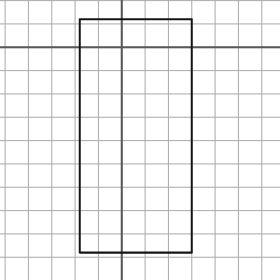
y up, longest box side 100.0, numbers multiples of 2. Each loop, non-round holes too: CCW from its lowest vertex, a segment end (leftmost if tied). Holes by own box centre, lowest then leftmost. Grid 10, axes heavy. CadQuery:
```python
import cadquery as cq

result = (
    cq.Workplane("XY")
    .moveTo(-18.0, -88.0)
    .lineTo(30.0, -88.0)
    .lineTo(30.0, 12.0)
    .lineTo(-18.0, 12.0)
    .close()
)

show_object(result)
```